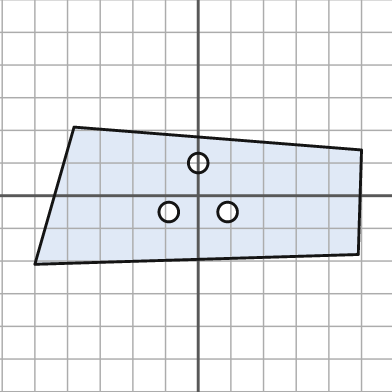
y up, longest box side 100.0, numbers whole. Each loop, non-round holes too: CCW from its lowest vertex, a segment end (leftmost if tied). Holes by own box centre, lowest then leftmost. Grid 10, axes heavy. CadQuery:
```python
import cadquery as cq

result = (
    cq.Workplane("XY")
    .moveTo(-50.0, -21.0)
    .lineTo(49.0, -18.0)
    .lineTo(50.0, 14.0)
    .lineTo(-38.0, 21.0)
    .close()
    .moveTo(-9.0, -5.0)
    .circle(3.0)
    .moveTo(9.0, -5.0)
    .circle(3.0)
    .moveTo(0.0, 10.0)
    .circle(3.0)
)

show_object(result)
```